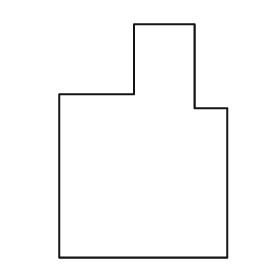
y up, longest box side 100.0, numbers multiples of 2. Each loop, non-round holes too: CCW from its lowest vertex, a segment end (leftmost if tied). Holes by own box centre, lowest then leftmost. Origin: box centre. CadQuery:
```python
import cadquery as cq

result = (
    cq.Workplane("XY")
    .moveTo(-36.0, -50.0)
    .lineTo(36.0, -50.0)
    .lineTo(36.0, 14.0)
    .lineTo(22.0, 14.0)
    .lineTo(22.0, 50.0)
    .lineTo(-4.0, 50.0)
    .lineTo(-4.0, 20.0)
    .lineTo(-36.0, 20.0)
    .close()
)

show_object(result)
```